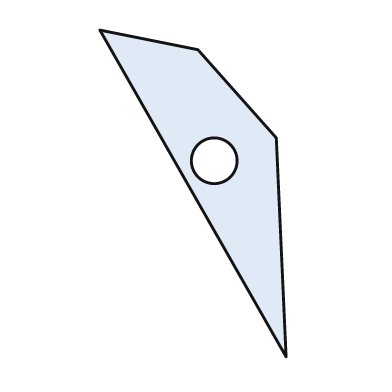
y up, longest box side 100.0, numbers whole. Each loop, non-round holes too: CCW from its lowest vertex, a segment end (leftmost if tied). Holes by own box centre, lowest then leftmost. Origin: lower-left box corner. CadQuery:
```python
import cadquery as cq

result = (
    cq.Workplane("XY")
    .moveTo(57.0, 0.0)
    .lineTo(54.0, 67.0)
    .lineTo(30.0, 94.0)
    .lineTo(0.0, 100.0)
    .close()
    .moveTo(35.0, 60.0)
    .circle(7.0)
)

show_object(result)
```